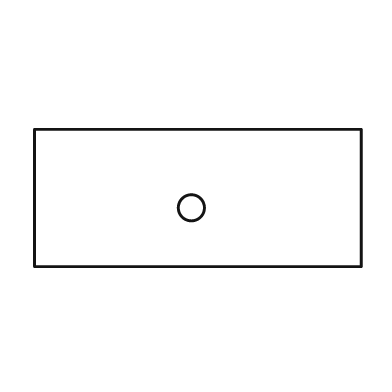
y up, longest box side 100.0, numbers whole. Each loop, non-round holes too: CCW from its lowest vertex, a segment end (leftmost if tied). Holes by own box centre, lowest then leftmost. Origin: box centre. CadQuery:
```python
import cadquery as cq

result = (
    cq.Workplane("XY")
    .moveTo(-50.0, -21.0)
    .lineTo(50.0, -21.0)
    .lineTo(50.0, 21.0)
    .lineTo(-50.0, 21.0)
    .close()
    .moveTo(-2.0, -3.0)
    .circle(4.0)
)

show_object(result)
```